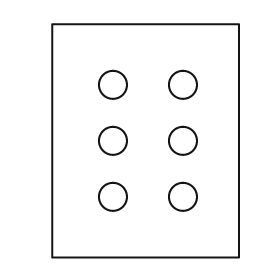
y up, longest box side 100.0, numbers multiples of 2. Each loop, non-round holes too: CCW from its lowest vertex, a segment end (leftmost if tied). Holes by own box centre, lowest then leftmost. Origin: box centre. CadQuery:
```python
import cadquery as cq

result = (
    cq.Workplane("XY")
    .moveTo(-40.0, -50.0)
    .lineTo(40.0, -50.0)
    .lineTo(40.0, 50.0)
    .lineTo(-40.0, 50.0)
    .close()
    .moveTo(-14.0, -24.0)
    .circle(6.0)
    .moveTo(16.0, -24.0)
    .circle(6.0)
    .moveTo(-14.0, 0.0)
    .circle(6.0)
    .moveTo(16.0, 0.0)
    .circle(6.0)
    .moveTo(-14.0, 24.0)
    .circle(6.0)
    .moveTo(16.0, 24.0)
    .circle(6.0)
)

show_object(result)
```